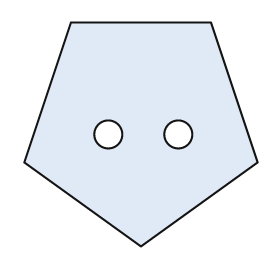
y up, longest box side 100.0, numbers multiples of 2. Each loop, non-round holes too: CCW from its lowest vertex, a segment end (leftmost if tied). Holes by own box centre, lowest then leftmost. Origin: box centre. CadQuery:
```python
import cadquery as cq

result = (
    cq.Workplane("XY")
    .moveTo(0.0, -48.0)
    .lineTo(50.0, -12.0)
    .lineTo(30.0, 48.0)
    .lineTo(-30.0, 48.0)
    .lineTo(-50.0, -12.0)
    .close()
    .moveTo(-14.0, 0.0)
    .circle(6.0)
    .moveTo(16.0, 0.0)
    .circle(6.0)
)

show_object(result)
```